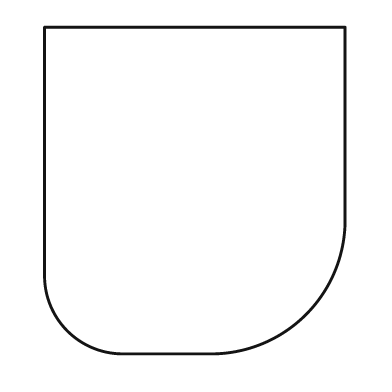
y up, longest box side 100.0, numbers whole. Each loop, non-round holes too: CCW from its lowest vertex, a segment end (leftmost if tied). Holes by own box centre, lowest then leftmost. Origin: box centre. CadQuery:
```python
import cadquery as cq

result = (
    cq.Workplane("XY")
    .moveTo(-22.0, -50.0)
    .lineTo(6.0, -50.0)
    .threePointArc((34.0, -38.0), (46.0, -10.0))
    .lineTo(46.0, 50.0)
    .lineTo(-46.0, 50.0)
    .lineTo(-46.0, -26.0)
    .threePointArc((-39.0, -43.0), (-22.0, -50.0))
    .close()
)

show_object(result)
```